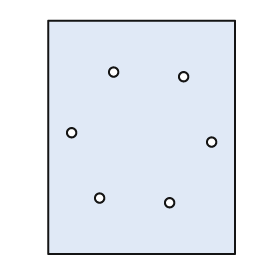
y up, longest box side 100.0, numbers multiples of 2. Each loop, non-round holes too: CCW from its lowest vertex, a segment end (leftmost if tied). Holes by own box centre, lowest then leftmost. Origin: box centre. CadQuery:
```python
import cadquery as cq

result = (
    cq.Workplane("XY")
    .moveTo(-40.0, -50.0)
    .lineTo(40.0, -50.0)
    .lineTo(40.0, 50.0)
    .lineTo(-40.0, 50.0)
    .close()
    .moveTo(12.0, -28.0)
    .circle(2.0)
    .moveTo(-18.0, -26.0)
    .circle(2.0)
    .moveTo(30.0, -2.0)
    .circle(2.0)
    .moveTo(-30.0, 2.0)
    .circle(2.0)
    .moveTo(18.0, 26.0)
    .circle(2.0)
    .moveTo(-12.0, 28.0)
    .circle(2.0)
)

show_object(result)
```